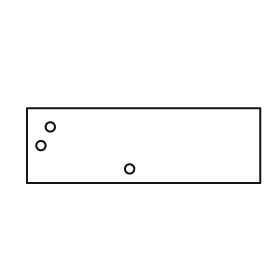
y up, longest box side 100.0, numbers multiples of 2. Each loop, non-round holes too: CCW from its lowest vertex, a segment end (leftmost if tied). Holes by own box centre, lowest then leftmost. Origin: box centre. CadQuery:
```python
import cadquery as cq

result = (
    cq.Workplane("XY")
    .moveTo(-50.0, -16.0)
    .lineTo(50.0, -16.0)
    .lineTo(50.0, 16.0)
    .lineTo(-50.0, 16.0)
    .close()
    .moveTo(-6.0, -10.0)
    .circle(2.0)
    .moveTo(-44.0, 0.0)
    .circle(2.0)
    .moveTo(-40.0, 8.0)
    .circle(2.0)
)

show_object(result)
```